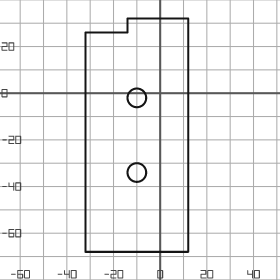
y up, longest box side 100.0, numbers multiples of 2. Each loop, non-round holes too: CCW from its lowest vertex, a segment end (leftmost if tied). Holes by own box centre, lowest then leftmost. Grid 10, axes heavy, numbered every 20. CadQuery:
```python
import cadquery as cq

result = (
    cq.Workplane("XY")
    .moveTo(-32.0, -68.0)
    .lineTo(12.0, -68.0)
    .lineTo(12.0, 32.0)
    .lineTo(-14.0, 32.0)
    .lineTo(-14.0, 26.0)
    .lineTo(-32.0, 26.0)
    .close()
    .moveTo(-10.0, -34.0)
    .circle(4.0)
    .moveTo(-10.0, -2.0)
    .circle(4.0)
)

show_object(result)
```